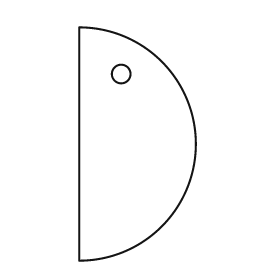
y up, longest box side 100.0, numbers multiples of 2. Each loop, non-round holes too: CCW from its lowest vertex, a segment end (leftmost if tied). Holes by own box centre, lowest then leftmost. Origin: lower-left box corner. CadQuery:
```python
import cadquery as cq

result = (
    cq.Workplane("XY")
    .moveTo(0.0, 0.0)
    .threePointArc((50.0, 50.0), (0.0, 100.0))
    .close()
    .moveTo(18.0, 80.0)
    .circle(4.0)
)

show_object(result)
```